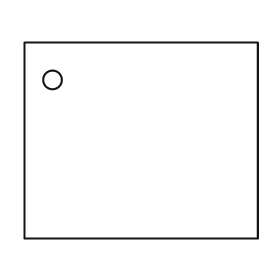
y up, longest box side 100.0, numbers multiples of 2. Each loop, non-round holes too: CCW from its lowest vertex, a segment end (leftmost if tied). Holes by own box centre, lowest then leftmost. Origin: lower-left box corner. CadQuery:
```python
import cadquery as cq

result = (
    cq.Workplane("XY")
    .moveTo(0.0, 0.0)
    .lineTo(100.0, 0.0)
    .lineTo(100.0, 84.0)
    .lineTo(0.0, 84.0)
    .close()
    .moveTo(12.0, 68.0)
    .circle(4.0)
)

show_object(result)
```